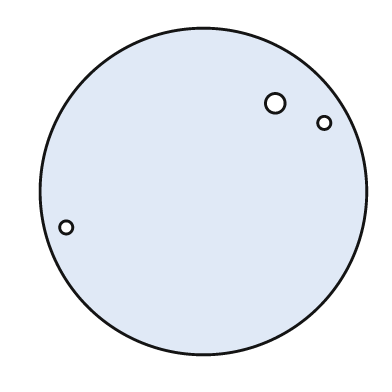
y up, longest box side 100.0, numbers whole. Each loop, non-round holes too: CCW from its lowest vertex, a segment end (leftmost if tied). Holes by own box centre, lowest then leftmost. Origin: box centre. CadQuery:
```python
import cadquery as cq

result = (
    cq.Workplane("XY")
    .moveTo(0.0, 0.0)
    .circle(50.0)
    .moveTo(-42.0, -11.0)
    .circle(2.0)
    .moveTo(37.0, 21.0)
    .circle(2.0)
    .moveTo(22.0, 27.0)
    .circle(3.0)
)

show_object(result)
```